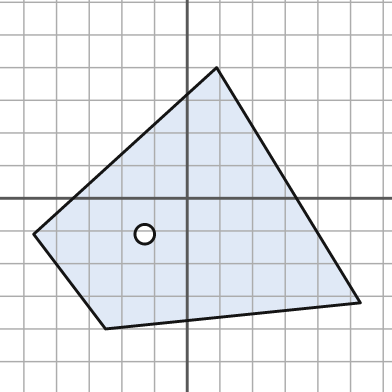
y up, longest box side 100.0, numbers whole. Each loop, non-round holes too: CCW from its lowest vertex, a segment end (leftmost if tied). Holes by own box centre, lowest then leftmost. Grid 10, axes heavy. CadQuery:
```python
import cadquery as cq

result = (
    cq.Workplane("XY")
    .moveTo(-25.0, -40.0)
    .lineTo(53.0, -32.0)
    .lineTo(9.0, 40.0)
    .lineTo(-47.0, -11.0)
    .close()
    .moveTo(-13.0, -11.0)
    .circle(3.0)
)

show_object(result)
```